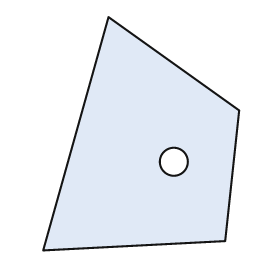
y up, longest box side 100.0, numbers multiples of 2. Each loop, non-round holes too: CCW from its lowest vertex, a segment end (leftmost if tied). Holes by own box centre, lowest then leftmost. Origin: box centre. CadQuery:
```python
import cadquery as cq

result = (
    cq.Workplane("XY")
    .moveTo(-42.0, -50.0)
    .lineTo(36.0, -46.0)
    .lineTo(42.0, 10.0)
    .lineTo(-14.0, 50.0)
    .close()
    .moveTo(14.0, -12.0)
    .circle(6.0)
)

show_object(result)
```